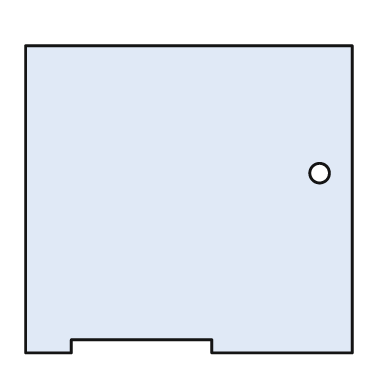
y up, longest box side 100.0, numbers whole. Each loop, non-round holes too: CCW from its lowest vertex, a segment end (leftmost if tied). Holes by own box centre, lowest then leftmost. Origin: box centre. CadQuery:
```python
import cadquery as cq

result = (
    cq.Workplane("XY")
    .moveTo(-50.0, -47.0)
    .lineTo(-36.0, -47.0)
    .lineTo(-36.0, -43.0)
    .lineTo(7.0, -43.0)
    .lineTo(7.0, -47.0)
    .lineTo(50.0, -47.0)
    .lineTo(50.0, 47.0)
    .lineTo(-50.0, 47.0)
    .close()
    .moveTo(40.0, 8.0)
    .circle(3.0)
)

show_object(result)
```